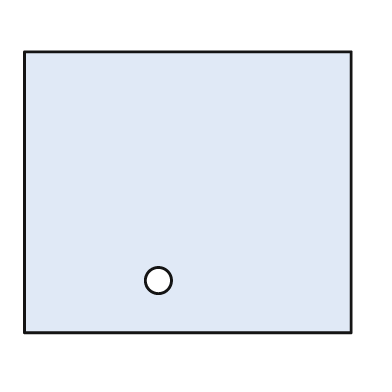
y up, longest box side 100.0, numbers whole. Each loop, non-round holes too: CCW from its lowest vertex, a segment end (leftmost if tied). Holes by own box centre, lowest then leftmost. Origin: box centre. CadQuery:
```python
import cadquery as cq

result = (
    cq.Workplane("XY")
    .moveTo(-50.0, -43.0)
    .lineTo(50.0, -43.0)
    .lineTo(50.0, 43.0)
    .lineTo(-50.0, 43.0)
    .close()
    .moveTo(-9.0, -27.0)
    .circle(4.0)
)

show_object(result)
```